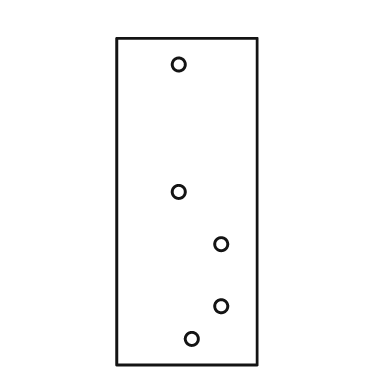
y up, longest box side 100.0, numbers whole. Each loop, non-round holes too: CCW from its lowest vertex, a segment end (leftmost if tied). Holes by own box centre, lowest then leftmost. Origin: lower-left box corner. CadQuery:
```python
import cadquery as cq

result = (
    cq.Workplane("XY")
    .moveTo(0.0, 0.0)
    .lineTo(43.0, 0.0)
    .lineTo(43.0, 100.0)
    .lineTo(0.0, 100.0)
    .close()
    .moveTo(23.0, 8.0)
    .circle(2.0)
    .moveTo(32.0, 18.0)
    .circle(2.0)
    .moveTo(32.0, 37.0)
    .circle(2.0)
    .moveTo(19.0, 53.0)
    .circle(2.0)
    .moveTo(19.0, 92.0)
    .circle(2.0)
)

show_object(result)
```